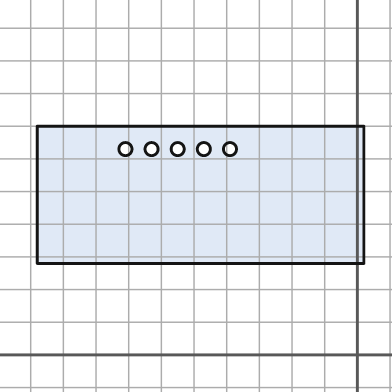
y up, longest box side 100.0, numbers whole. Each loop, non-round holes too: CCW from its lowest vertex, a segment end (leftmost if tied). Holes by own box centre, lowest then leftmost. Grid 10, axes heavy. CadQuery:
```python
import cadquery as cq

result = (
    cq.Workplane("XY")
    .moveTo(-98.0, 28.0)
    .lineTo(2.0, 28.0)
    .lineTo(2.0, 70.0)
    .lineTo(-98.0, 70.0)
    .close()
    .moveTo(-71.0, 63.0)
    .circle(2.0)
    .moveTo(-63.0, 63.0)
    .circle(2.0)
    .moveTo(-55.0, 63.0)
    .circle(2.0)
    .moveTo(-47.0, 63.0)
    .circle(2.0)
    .moveTo(-39.0, 63.0)
    .circle(2.0)
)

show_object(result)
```